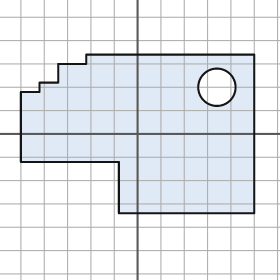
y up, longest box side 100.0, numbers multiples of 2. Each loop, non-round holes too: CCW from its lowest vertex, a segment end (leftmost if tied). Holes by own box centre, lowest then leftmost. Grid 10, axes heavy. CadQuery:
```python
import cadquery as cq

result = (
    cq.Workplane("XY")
    .moveTo(-8.0, -34.0)
    .lineTo(50.0, -34.0)
    .lineTo(50.0, 34.0)
    .lineTo(-22.0, 34.0)
    .lineTo(-22.0, 30.0)
    .lineTo(-34.0, 30.0)
    .lineTo(-34.0, 22.0)
    .lineTo(-42.0, 22.0)
    .lineTo(-42.0, 18.0)
    .lineTo(-50.0, 18.0)
    .lineTo(-50.0, -12.0)
    .lineTo(-8.0, -12.0)
    .close()
    .moveTo(34.0, 20.0)
    .circle(8.0)
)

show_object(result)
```